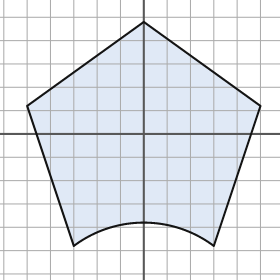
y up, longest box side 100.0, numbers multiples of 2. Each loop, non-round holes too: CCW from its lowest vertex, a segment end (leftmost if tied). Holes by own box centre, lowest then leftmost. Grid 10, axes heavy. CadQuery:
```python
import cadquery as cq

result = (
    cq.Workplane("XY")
    .moveTo(-30.0, -48.0)
    .threePointArc((0.0, -38.0), (30.0, -48.0))
    .lineTo(50.0, 12.0)
    .lineTo(0.0, 48.0)
    .lineTo(-50.0, 12.0)
    .close()
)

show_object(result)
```